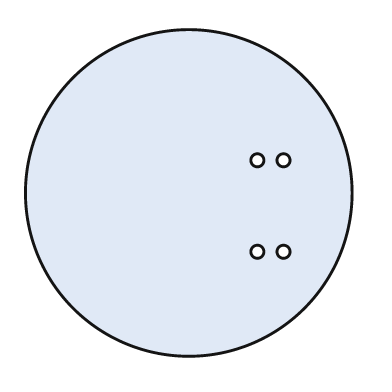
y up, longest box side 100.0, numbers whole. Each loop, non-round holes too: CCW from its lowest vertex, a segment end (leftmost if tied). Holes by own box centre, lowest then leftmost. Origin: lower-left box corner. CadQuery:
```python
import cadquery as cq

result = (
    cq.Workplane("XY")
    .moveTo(50.0, 50.0)
    .circle(50.0)
    .moveTo(71.0, 32.0)
    .circle(2.0)
    .moveTo(79.0, 32.0)
    .circle(2.0)
    .moveTo(71.0, 60.0)
    .circle(2.0)
    .moveTo(79.0, 60.0)
    .circle(2.0)
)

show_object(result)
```